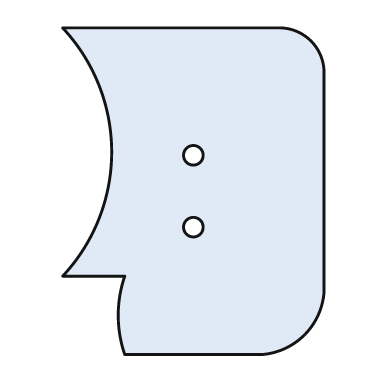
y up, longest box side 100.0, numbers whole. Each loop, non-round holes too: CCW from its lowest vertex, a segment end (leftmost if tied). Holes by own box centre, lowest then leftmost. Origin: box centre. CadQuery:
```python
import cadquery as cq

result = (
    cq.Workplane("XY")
    .moveTo(-21.0, -50.0)
    .lineTo(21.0, -50.0)
    .threePointArc((34.0, -44.0), (40.0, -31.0))
    .lineTo(40.0, 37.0)
    .threePointArc((36.0, 46.0), (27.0, 50.0))
    .lineTo(-40.0, 50.0)
    .threePointArc((-25.0, 12.0), (-40.0, -26.0))
    .lineTo(-21.0, -26.0)
    .threePointArc((-23.0, -38.0), (-21.0, -50.0))
    .close()
    .moveTo(0.0, -11.0)
    .circle(3.0)
    .moveTo(0.0, 11.0)
    .circle(3.0)
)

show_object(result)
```